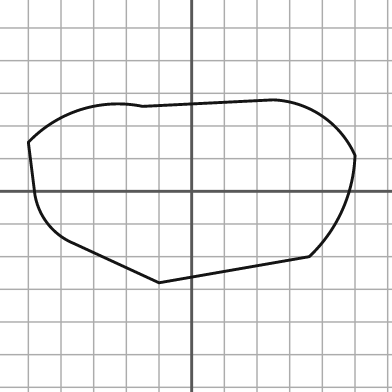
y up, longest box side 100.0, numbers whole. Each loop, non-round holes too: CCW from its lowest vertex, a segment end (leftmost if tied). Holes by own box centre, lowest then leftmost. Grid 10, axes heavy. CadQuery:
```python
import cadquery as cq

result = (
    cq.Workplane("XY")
    .moveTo(-10.0, -28.0)
    .lineTo(36.0, -20.0)
    .threePointArc((46.0, -6.0), (50.0, 11.0))
    .threePointArc((40.0, 23.0), (25.0, 28.0))
    .lineTo(-15.0, 26.0)
    .threePointArc((-34.0, 25.0), (-50.0, 15.0))
    .lineTo(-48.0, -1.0)
    .threePointArc((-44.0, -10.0), (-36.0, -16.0))
    .close()
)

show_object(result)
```